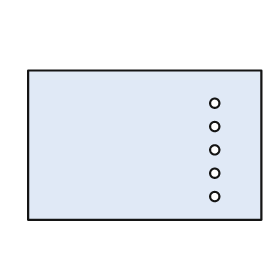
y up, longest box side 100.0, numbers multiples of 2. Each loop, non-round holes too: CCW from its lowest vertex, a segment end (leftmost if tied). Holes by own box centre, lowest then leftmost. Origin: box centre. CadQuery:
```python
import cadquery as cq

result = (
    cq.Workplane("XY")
    .moveTo(-50.0, -32.0)
    .lineTo(50.0, -32.0)
    .lineTo(50.0, 32.0)
    .lineTo(-50.0, 32.0)
    .close()
    .moveTo(30.0, -22.0)
    .circle(2.0)
    .moveTo(30.0, -12.0)
    .circle(2.0)
    .moveTo(30.0, -2.0)
    .circle(2.0)
    .moveTo(30.0, 8.0)
    .circle(2.0)
    .moveTo(30.0, 18.0)
    .circle(2.0)
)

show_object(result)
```